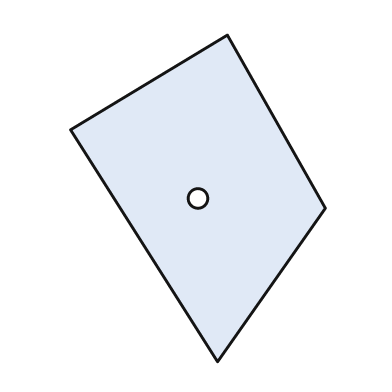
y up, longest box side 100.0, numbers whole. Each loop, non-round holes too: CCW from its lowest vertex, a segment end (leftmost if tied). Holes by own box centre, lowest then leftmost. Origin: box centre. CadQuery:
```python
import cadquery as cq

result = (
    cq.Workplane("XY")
    .moveTo(6.0, -50.0)
    .lineTo(39.0, -3.0)
    .lineTo(9.0, 50.0)
    .lineTo(-39.0, 21.0)
    .close()
    .moveTo(0.0, 0.0)
    .circle(3.0)
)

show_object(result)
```